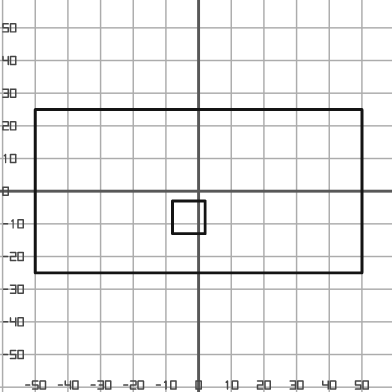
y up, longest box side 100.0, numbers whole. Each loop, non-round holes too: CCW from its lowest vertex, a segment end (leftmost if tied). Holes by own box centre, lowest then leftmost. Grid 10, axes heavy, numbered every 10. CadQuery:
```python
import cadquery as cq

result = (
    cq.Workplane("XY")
    .moveTo(-50.0, -25.0)
    .lineTo(50.0, -25.0)
    .lineTo(50.0, 25.0)
    .lineTo(-50.0, 25.0)
    .close()
    .moveTo(-8.0, -13.0)
    .lineTo(2.0, -13.0)
    .lineTo(2.0, -3.0)
    .lineTo(-8.0, -3.0)
    .close()
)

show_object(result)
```